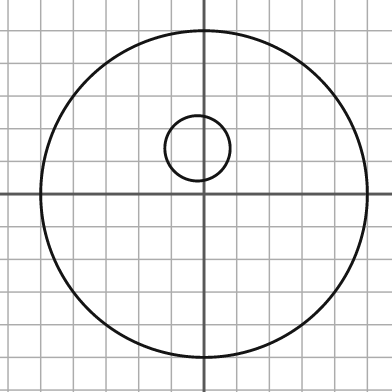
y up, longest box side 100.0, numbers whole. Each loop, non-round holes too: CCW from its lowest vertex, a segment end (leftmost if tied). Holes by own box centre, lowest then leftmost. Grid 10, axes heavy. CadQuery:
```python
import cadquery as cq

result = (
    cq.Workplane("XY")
    .moveTo(0.0, 0.0)
    .circle(50.0)
    .moveTo(-2.0, 14.0)
    .circle(10.0)
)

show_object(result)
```